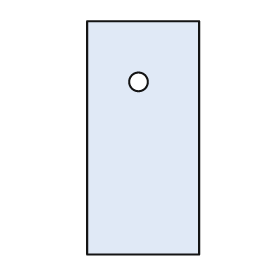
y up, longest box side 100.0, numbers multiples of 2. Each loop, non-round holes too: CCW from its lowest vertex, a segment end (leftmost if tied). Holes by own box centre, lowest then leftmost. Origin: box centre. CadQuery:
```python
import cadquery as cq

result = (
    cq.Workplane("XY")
    .moveTo(-24.0, -50.0)
    .lineTo(24.0, -50.0)
    .lineTo(24.0, 50.0)
    .lineTo(-24.0, 50.0)
    .close()
    .moveTo(-2.0, 24.0)
    .circle(4.0)
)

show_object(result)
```